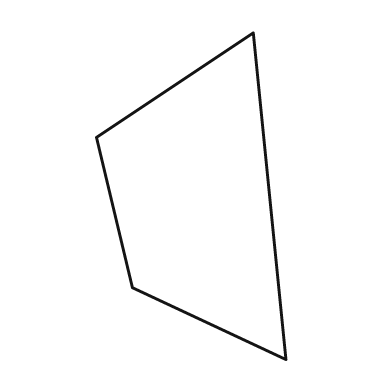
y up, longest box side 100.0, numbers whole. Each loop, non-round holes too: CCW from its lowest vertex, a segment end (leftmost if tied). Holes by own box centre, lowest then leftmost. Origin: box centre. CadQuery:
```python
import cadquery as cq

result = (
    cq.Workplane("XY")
    .moveTo(29.0, -50.0)
    .lineTo(19.0, 50.0)
    .lineTo(-29.0, 18.0)
    .lineTo(-18.0, -28.0)
    .close()
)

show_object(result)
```